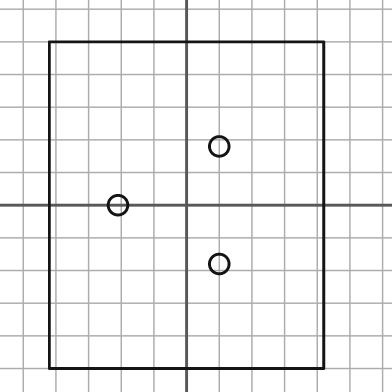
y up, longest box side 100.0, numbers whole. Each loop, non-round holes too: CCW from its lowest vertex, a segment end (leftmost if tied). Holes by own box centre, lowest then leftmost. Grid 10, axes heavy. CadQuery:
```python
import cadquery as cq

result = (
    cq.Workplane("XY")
    .moveTo(-42.0, -50.0)
    .lineTo(42.0, -50.0)
    .lineTo(42.0, 50.0)
    .lineTo(-42.0, 50.0)
    .close()
    .moveTo(10.0, -18.0)
    .circle(3.0)
    .moveTo(-21.0, 0.0)
    .circle(3.0)
    .moveTo(10.0, 18.0)
    .circle(3.0)
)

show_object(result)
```